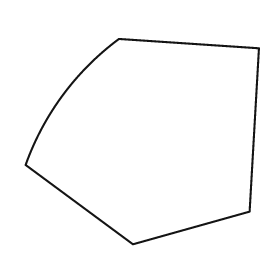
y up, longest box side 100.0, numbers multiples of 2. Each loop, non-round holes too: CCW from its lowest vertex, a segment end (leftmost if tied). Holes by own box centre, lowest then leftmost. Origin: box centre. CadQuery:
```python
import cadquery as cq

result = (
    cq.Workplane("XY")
    .moveTo(-4.0, -44.0)
    .lineTo(46.0, -30.0)
    .lineTo(50.0, 40.0)
    .lineTo(-10.0, 44.0)
    .threePointArc((-34.0, 20.0), (-50.0, -10.0))
    .close()
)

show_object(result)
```